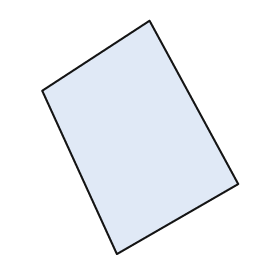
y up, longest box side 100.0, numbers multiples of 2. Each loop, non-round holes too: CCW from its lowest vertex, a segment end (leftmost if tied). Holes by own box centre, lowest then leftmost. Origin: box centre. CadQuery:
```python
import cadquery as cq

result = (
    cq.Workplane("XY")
    .moveTo(-10.0, -50.0)
    .lineTo(42.0, -20.0)
    .lineTo(4.0, 50.0)
    .lineTo(-42.0, 20.0)
    .close()
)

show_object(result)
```